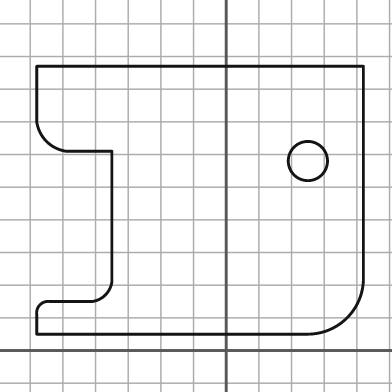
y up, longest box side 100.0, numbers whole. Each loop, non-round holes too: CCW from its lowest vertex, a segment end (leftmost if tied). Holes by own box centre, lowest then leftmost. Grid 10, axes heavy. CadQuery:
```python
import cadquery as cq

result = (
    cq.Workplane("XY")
    .moveTo(-58.0, 5.0)
    .lineTo(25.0, 5.0)
    .threePointArc((37.0, 10.0), (42.0, 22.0))
    .lineTo(42.0, 87.0)
    .lineTo(-58.0, 87.0)
    .lineTo(-58.0, 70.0)
    .threePointArc((-55.0, 64.0), (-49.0, 61.0))
    .lineTo(-35.0, 61.0)
    .lineTo(-35.0, 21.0)
    .threePointArc((-37.0, 17.0), (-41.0, 15.0))
    .lineTo(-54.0, 15.0)
    .threePointArc((-57.0, 14.0), (-58.0, 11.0))
    .close()
    .moveTo(25.0, 58.0)
    .circle(6.0)
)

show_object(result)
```